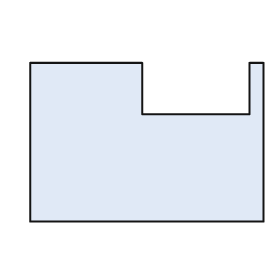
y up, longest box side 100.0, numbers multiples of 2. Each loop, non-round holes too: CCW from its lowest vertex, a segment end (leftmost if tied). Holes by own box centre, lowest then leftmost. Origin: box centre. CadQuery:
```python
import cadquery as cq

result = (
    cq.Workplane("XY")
    .moveTo(-50.0, -34.0)
    .lineTo(50.0, -34.0)
    .lineTo(50.0, 34.0)
    .lineTo(44.0, 34.0)
    .lineTo(44.0, 12.0)
    .lineTo(-2.0, 12.0)
    .lineTo(-2.0, 34.0)
    .lineTo(-50.0, 34.0)
    .close()
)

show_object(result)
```